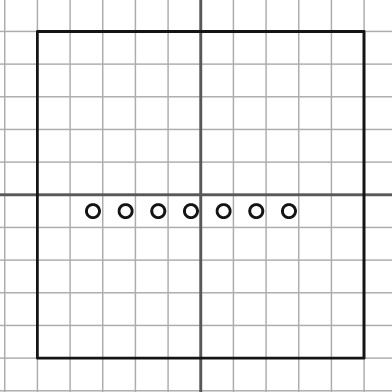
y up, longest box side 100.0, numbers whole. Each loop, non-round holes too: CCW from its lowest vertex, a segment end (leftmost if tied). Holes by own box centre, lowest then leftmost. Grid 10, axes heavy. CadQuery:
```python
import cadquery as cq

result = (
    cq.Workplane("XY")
    .moveTo(-50.0, -50.0)
    .lineTo(50.0, -50.0)
    .lineTo(50.0, 50.0)
    .lineTo(-50.0, 50.0)
    .close()
    .moveTo(-33.0, -5.0)
    .circle(2.0)
    .moveTo(-23.0, -5.0)
    .circle(2.0)
    .moveTo(-13.0, -5.0)
    .circle(2.0)
    .moveTo(-3.0, -5.0)
    .circle(2.0)
    .moveTo(7.0, -5.0)
    .circle(2.0)
    .moveTo(17.0, -5.0)
    .circle(2.0)
    .moveTo(27.0, -5.0)
    .circle(2.0)
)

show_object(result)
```